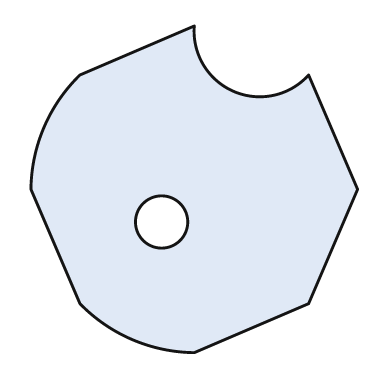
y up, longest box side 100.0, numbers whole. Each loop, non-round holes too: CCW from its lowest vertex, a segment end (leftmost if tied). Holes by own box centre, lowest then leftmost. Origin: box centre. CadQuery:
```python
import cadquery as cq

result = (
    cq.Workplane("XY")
    .moveTo(0.0, -50.0)
    .lineTo(35.0, -35.0)
    .lineTo(50.0, 0.0)
    .lineTo(35.0, 35.0)
    .threePointArc((12.0, 30.0), (0.0, 50.0))
    .lineTo(-35.0, 35.0)
    .threePointArc((-46.0, 19.0), (-50.0, 0.0))
    .lineTo(-35.0, -35.0)
    .threePointArc((-19.0, -46.0), (0.0, -50.0))
    .close()
    .moveTo(-10.0, -10.0)
    .circle(8.0)
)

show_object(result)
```